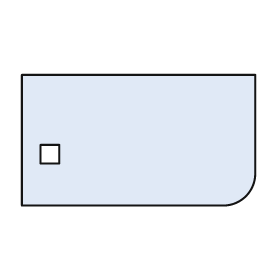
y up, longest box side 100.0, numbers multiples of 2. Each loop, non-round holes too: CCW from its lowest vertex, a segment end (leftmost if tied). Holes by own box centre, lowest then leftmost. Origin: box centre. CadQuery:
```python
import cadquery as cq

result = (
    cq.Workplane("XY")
    .moveTo(-50.0, -28.0)
    .lineTo(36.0, -28.0)
    .threePointArc((46.0, -24.0), (50.0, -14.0))
    .lineTo(50.0, 28.0)
    .lineTo(-50.0, 28.0)
    .close()
    .moveTo(-42.0, -10.0)
    .lineTo(-34.0, -10.0)
    .lineTo(-34.0, -2.0)
    .lineTo(-42.0, -2.0)
    .close()
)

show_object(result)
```